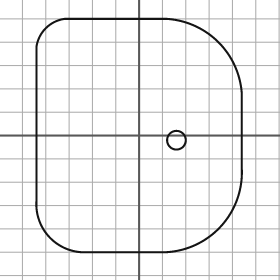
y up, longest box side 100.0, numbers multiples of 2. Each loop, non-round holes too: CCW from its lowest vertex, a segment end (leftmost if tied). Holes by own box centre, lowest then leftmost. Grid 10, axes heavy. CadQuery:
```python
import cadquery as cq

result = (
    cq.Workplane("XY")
    .moveTo(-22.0, -50.0)
    .lineTo(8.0, -50.0)
    .threePointArc((34.0, -40.0), (44.0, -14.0))
    .lineTo(44.0, 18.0)
    .threePointArc((34.0, 40.0), (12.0, 50.0))
    .lineTo(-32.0, 50.0)
    .threePointArc((-40.0, 46.0), (-44.0, 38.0))
    .lineTo(-44.0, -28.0)
    .threePointArc((-38.0, -44.0), (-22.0, -50.0))
    .close()
    .moveTo(16.0, -2.0)
    .circle(4.0)
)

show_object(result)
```